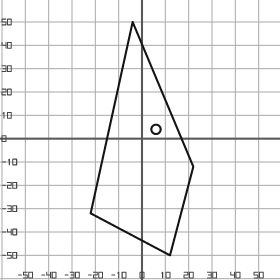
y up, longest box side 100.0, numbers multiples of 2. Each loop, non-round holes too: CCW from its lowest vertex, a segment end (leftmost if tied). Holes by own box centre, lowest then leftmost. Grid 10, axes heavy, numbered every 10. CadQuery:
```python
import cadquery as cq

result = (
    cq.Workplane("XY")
    .moveTo(12.0, -50.0)
    .lineTo(22.0, -12.0)
    .lineTo(-4.0, 50.0)
    .lineTo(-22.0, -32.0)
    .close()
    .moveTo(6.0, 4.0)
    .circle(2.0)
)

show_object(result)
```